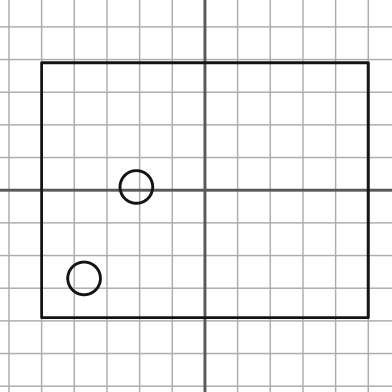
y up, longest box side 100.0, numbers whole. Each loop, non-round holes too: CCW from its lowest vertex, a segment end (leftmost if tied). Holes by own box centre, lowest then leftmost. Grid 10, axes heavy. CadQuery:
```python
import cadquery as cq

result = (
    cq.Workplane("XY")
    .moveTo(-50.0, -39.0)
    .lineTo(50.0, -39.0)
    .lineTo(50.0, 39.0)
    .lineTo(-50.0, 39.0)
    .close()
    .moveTo(-37.0, -27.0)
    .circle(5.0)
    .moveTo(-21.0, 1.0)
    .circle(5.0)
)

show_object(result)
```